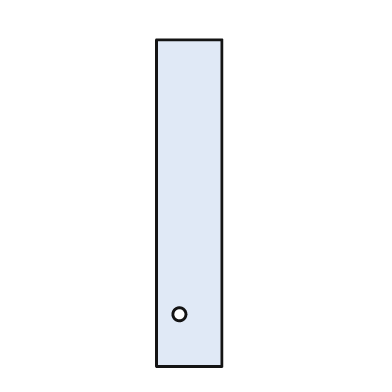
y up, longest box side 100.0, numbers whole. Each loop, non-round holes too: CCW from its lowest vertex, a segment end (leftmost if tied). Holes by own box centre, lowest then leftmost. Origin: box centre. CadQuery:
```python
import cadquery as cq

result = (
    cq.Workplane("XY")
    .moveTo(-10.0, -50.0)
    .lineTo(10.0, -50.0)
    .lineTo(10.0, 50.0)
    .lineTo(-10.0, 50.0)
    .close()
    .moveTo(-3.0, -34.0)
    .circle(2.0)
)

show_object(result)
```